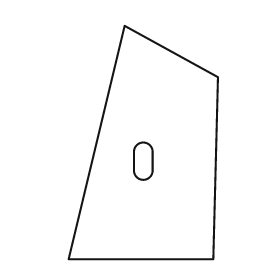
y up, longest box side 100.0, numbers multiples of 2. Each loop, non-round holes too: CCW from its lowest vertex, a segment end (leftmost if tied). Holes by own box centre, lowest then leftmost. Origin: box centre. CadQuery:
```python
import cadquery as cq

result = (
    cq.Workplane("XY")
    .moveTo(-32.0, -50.0)
    .lineTo(30.0, -50.0)
    .lineTo(32.0, 28.0)
    .lineTo(-8.0, 50.0)
    .close()
    .moveTo(-4.0, -12.0)
    .threePointArc((0.0, -16.0), (4.0, -12.0))
    .lineTo(4.0, -4.0)
    .threePointArc((0.0, 0.0), (-4.0, -4.0))
    .close()
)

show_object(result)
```